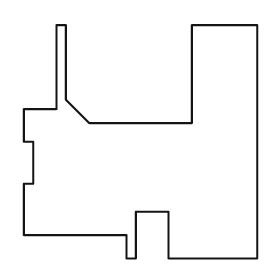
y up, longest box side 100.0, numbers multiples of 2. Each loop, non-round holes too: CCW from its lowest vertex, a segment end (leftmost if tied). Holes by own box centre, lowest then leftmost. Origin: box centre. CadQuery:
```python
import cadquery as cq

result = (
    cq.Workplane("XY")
    .moveTo(-6.0, -50.0)
    .lineTo(-2.0, -50.0)
    .lineTo(-2.0, -30.0)
    .lineTo(12.0, -30.0)
    .lineTo(12.0, -50.0)
    .lineTo(50.0, -50.0)
    .lineTo(50.0, 50.0)
    .lineTo(22.0, 50.0)
    .lineTo(22.0, 8.0)
    .lineTo(-22.0, 8.0)
    .lineTo(-32.0, 18.0)
    .lineTo(-32.0, 50.0)
    .lineTo(-36.0, 50.0)
    .lineTo(-36.0, 14.0)
    .lineTo(-50.0, 14.0)
    .lineTo(-50.0, 0.0)
    .lineTo(-46.0, 0.0)
    .lineTo(-46.0, -18.0)
    .lineTo(-50.0, -18.0)
    .lineTo(-50.0, -40.0)
    .lineTo(-6.0, -40.0)
    .close()
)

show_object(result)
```